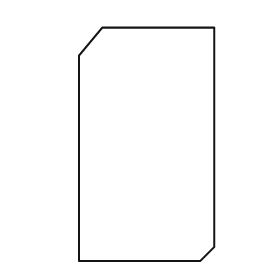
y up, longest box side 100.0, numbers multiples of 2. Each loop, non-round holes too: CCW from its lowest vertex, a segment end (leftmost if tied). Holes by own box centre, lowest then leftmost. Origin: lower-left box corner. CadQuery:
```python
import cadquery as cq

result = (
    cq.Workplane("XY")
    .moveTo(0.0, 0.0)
    .lineTo(52.0, 0.0)
    .lineTo(58.0, 6.0)
    .lineTo(58.0, 100.0)
    .lineTo(10.0, 100.0)
    .lineTo(0.0, 88.0)
    .close()
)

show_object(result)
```